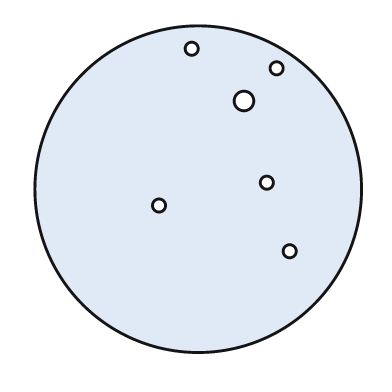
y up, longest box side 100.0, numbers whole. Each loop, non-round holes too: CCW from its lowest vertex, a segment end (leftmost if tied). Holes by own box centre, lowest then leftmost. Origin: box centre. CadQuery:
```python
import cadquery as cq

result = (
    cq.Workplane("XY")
    .moveTo(0.0, 0.0)
    .circle(50.0)
    .moveTo(28.0, -19.0)
    .circle(2.0)
    .moveTo(-12.0, -5.0)
    .circle(2.0)
    .moveTo(21.0, 2.0)
    .circle(2.0)
    .moveTo(14.0, 27.0)
    .circle(3.0)
    .moveTo(24.0, 37.0)
    .circle(2.0)
    .moveTo(-2.0, 43.0)
    .circle(2.0)
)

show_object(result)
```